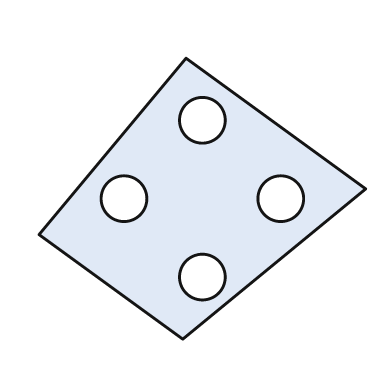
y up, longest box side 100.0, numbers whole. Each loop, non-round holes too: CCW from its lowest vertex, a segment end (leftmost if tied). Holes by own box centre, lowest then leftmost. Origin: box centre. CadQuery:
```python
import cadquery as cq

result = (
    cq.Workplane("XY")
    .moveTo(-6.0, -43.0)
    .lineTo(50.0, 3.0)
    .lineTo(-5.0, 43.0)
    .lineTo(-50.0, -11.0)
    .close()
    .moveTo(0.0, -24.0)
    .circle(7.0)
    .moveTo(-24.0, 0.0)
    .circle(7.0)
    .moveTo(24.0, 0.0)
    .circle(7.0)
    .moveTo(0.0, 24.0)
    .circle(7.0)
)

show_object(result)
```